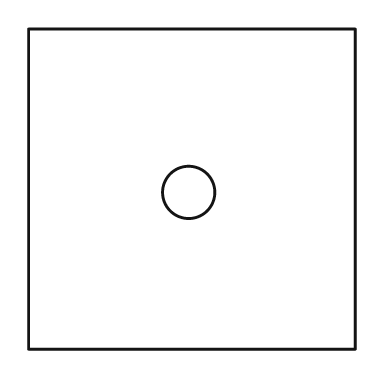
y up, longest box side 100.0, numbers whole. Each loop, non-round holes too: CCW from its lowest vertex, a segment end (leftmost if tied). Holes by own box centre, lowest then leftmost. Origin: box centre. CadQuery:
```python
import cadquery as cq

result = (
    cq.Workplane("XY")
    .moveTo(-50.0, -49.0)
    .lineTo(50.0, -49.0)
    .lineTo(50.0, 49.0)
    .lineTo(-50.0, 49.0)
    .close()
    .moveTo(-1.0, -1.0)
    .circle(8.0)
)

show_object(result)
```